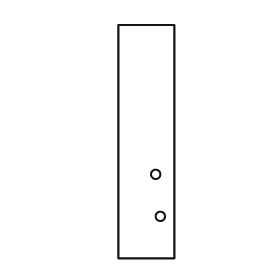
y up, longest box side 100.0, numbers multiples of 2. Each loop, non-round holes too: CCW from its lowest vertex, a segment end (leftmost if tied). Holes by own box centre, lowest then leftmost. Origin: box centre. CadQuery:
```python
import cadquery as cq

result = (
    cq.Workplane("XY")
    .moveTo(-12.0, -50.0)
    .lineTo(12.0, -50.0)
    .lineTo(12.0, 50.0)
    .lineTo(-12.0, 50.0)
    .close()
    .moveTo(6.0, -32.0)
    .circle(2.0)
    .moveTo(4.0, -14.0)
    .circle(2.0)
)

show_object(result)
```